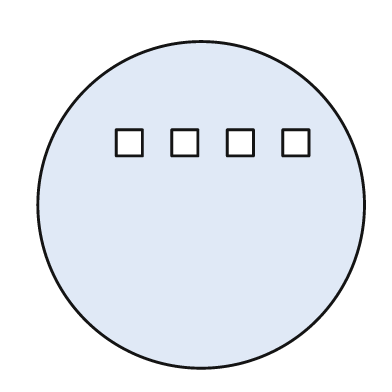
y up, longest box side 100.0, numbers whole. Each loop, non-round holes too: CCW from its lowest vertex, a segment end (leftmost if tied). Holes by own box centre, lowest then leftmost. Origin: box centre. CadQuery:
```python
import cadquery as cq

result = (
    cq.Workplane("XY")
    .moveTo(0.0, 0.0)
    .circle(50.0)
    .moveTo(-26.0, 15.0)
    .lineTo(-18.0, 15.0)
    .lineTo(-18.0, 23.0)
    .lineTo(-26.0, 23.0)
    .close()
    .moveTo(-9.0, 15.0)
    .lineTo(-1.0, 15.0)
    .lineTo(-1.0, 23.0)
    .lineTo(-9.0, 23.0)
    .close()
    .moveTo(8.0, 15.0)
    .lineTo(16.0, 15.0)
    .lineTo(16.0, 23.0)
    .lineTo(8.0, 23.0)
    .close()
    .moveTo(25.0, 15.0)
    .lineTo(33.0, 15.0)
    .lineTo(33.0, 23.0)
    .lineTo(25.0, 23.0)
    .close()
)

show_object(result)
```